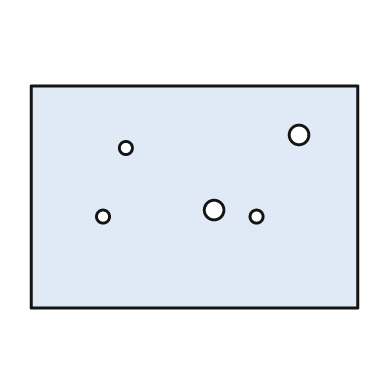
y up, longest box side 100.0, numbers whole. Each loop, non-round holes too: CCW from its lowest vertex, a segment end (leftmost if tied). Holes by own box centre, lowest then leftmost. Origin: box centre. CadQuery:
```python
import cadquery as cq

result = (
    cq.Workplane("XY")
    .moveTo(-50.0, -34.0)
    .lineTo(50.0, -34.0)
    .lineTo(50.0, 34.0)
    .lineTo(-50.0, 34.0)
    .close()
    .moveTo(-28.0, -6.0)
    .circle(2.0)
    .moveTo(19.0, -6.0)
    .circle(2.0)
    .moveTo(6.0, -4.0)
    .circle(3.0)
    .moveTo(-21.0, 15.0)
    .circle(2.0)
    .moveTo(32.0, 19.0)
    .circle(3.0)
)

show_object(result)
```